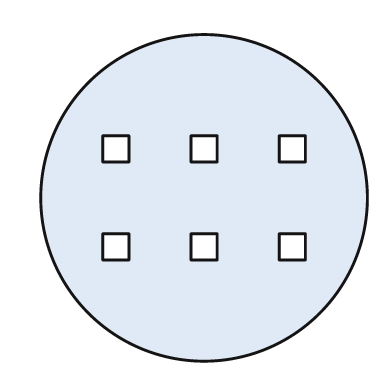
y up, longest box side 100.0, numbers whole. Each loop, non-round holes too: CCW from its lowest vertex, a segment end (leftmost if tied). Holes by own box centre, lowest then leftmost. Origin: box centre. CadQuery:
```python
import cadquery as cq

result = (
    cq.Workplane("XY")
    .moveTo(0.0, 0.0)
    .circle(50.0)
    .moveTo(-31.0, -19.0)
    .lineTo(-23.0, -19.0)
    .lineTo(-23.0, -11.0)
    .lineTo(-31.0, -11.0)
    .close()
    .moveTo(-4.0, -19.0)
    .lineTo(4.0, -19.0)
    .lineTo(4.0, -11.0)
    .lineTo(-4.0, -11.0)
    .close()
    .moveTo(23.0, -19.0)
    .lineTo(31.0, -19.0)
    .lineTo(31.0, -11.0)
    .lineTo(23.0, -11.0)
    .close()
    .moveTo(-31.0, 11.0)
    .lineTo(-23.0, 11.0)
    .lineTo(-23.0, 19.0)
    .lineTo(-31.0, 19.0)
    .close()
    .moveTo(-4.0, 11.0)
    .lineTo(4.0, 11.0)
    .lineTo(4.0, 19.0)
    .lineTo(-4.0, 19.0)
    .close()
    .moveTo(23.0, 11.0)
    .lineTo(31.0, 11.0)
    .lineTo(31.0, 19.0)
    .lineTo(23.0, 19.0)
    .close()
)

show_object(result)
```